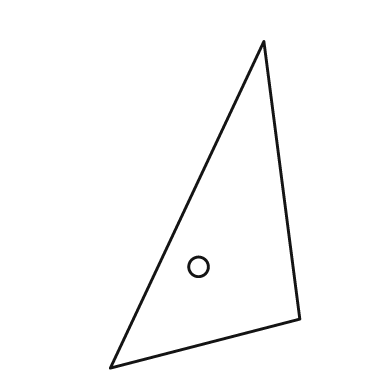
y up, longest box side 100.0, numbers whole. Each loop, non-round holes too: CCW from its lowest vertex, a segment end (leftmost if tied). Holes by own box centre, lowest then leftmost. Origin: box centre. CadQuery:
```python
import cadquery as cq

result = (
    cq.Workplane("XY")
    .moveTo(-29.0, -50.0)
    .lineTo(29.0, -35.0)
    .lineTo(18.0, 50.0)
    .close()
    .moveTo(-2.0, -19.0)
    .circle(3.0)
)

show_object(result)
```